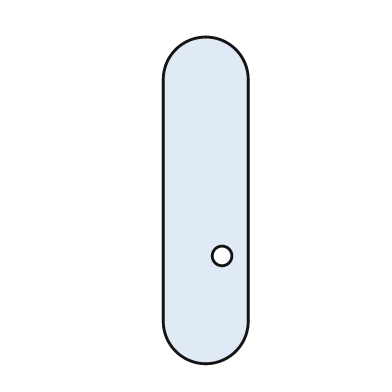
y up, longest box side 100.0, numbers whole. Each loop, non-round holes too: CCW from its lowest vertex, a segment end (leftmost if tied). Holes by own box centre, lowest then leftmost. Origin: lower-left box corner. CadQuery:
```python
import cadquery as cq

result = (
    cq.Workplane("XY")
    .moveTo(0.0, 13.0)
    .threePointArc((13.0, 0.0), (26.0, 13.0))
    .lineTo(26.0, 87.0)
    .threePointArc((13.0, 100.0), (0.0, 87.0))
    .close()
    .moveTo(18.0, 33.0)
    .circle(3.0)
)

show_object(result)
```